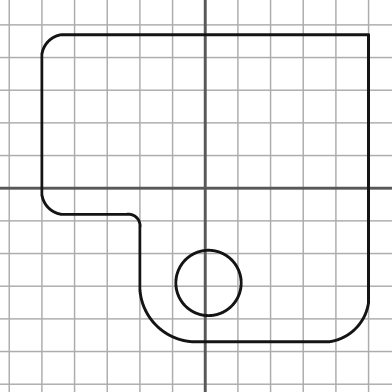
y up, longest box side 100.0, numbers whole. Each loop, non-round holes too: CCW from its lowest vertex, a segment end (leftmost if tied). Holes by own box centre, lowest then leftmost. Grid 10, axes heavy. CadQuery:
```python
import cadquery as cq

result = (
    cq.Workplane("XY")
    .moveTo(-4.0, -47.0)
    .lineTo(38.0, -47.0)
    .threePointArc((46.0, -43.0), (50.0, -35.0))
    .lineTo(50.0, 47.0)
    .lineTo(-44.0, 47.0)
    .threePointArc((-48.0, 45.0), (-50.0, 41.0))
    .lineTo(-50.0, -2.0)
    .threePointArc((-48.0, -6.0), (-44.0, -8.0))
    .lineTo(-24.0, -8.0)
    .threePointArc((-21.0, -9.0), (-20.0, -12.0))
    .lineTo(-20.0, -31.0)
    .threePointArc((-15.0, -42.0), (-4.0, -47.0))
    .close()
    .moveTo(1.0, -29.0)
    .circle(10.0)
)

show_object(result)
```